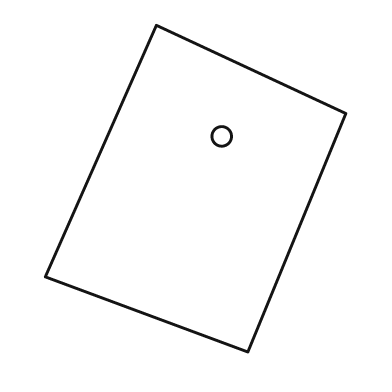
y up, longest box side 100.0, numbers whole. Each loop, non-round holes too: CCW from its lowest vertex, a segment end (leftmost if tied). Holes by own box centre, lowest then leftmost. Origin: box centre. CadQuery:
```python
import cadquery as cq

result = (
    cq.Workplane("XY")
    .moveTo(16.0, -50.0)
    .lineTo(46.0, 23.0)
    .lineTo(-12.0, 50.0)
    .lineTo(-46.0, -27.0)
    .close()
    .moveTo(8.0, 16.0)
    .circle(3.0)
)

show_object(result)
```